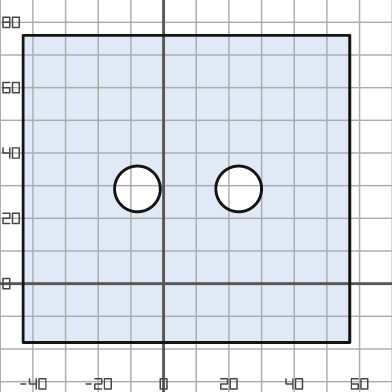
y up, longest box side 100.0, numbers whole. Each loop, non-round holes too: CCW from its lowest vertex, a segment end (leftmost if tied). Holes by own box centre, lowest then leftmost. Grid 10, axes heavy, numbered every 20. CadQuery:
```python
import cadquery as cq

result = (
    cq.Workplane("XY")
    .moveTo(-43.0, -18.0)
    .lineTo(57.0, -18.0)
    .lineTo(57.0, 76.0)
    .lineTo(-43.0, 76.0)
    .close()
    .moveTo(-8.0, 29.0)
    .circle(7.0)
    .moveTo(23.0, 29.0)
    .circle(7.0)
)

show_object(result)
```